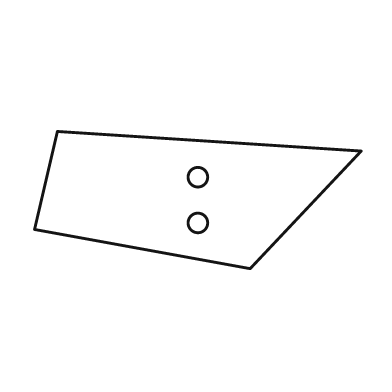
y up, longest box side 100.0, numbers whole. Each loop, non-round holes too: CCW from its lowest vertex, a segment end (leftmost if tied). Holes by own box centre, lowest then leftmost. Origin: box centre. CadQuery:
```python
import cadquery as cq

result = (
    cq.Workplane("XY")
    .moveTo(16.0, -21.0)
    .lineTo(50.0, 15.0)
    .lineTo(-43.0, 21.0)
    .lineTo(-50.0, -9.0)
    .close()
    .moveTo(0.0, -7.0)
    .circle(3.0)
    .moveTo(0.0, 7.0)
    .circle(3.0)
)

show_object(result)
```